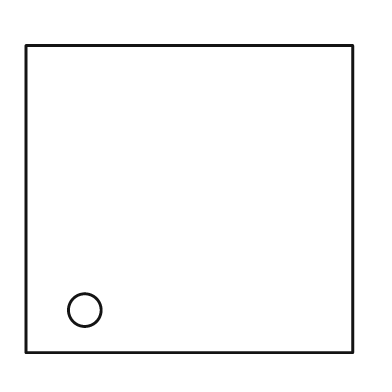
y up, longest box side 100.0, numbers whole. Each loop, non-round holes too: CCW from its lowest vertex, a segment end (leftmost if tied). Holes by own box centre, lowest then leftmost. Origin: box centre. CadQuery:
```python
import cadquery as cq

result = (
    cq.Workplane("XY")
    .moveTo(-50.0, -47.0)
    .lineTo(50.0, -47.0)
    .lineTo(50.0, 47.0)
    .lineTo(-50.0, 47.0)
    .close()
    .moveTo(-32.0, -34.0)
    .circle(5.0)
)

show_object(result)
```